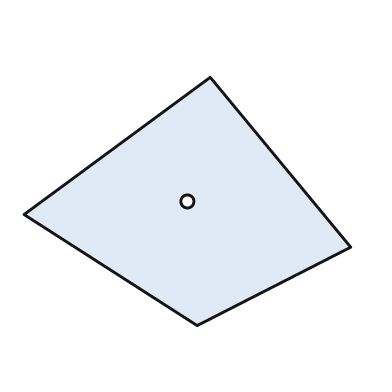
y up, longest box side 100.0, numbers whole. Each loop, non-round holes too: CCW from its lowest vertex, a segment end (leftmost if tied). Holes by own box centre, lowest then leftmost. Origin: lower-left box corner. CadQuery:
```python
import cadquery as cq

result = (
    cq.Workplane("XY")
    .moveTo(53.0, 0.0)
    .lineTo(100.0, 24.0)
    .lineTo(57.0, 76.0)
    .lineTo(0.0, 34.0)
    .close()
    .moveTo(50.0, 38.0)
    .circle(2.0)
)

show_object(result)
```